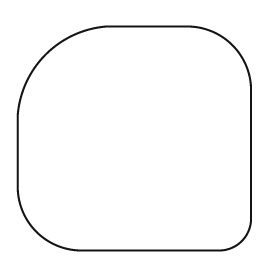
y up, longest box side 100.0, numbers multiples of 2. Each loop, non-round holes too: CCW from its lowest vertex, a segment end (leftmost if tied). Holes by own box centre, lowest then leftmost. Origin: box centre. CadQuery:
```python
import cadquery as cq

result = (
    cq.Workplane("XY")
    .moveTo(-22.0, -48.0)
    .lineTo(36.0, -48.0)
    .threePointArc((46.0, -44.0), (50.0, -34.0))
    .lineTo(50.0, 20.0)
    .threePointArc((42.0, 40.0), (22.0, 48.0))
    .lineTo(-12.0, 48.0)
    .threePointArc((-38.0, 36.0), (-50.0, 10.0))
    .lineTo(-50.0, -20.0)
    .threePointArc((-42.0, -40.0), (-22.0, -48.0))
    .close()
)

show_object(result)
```